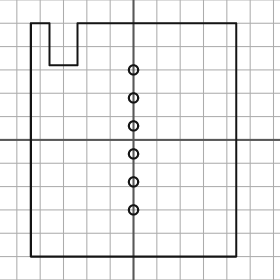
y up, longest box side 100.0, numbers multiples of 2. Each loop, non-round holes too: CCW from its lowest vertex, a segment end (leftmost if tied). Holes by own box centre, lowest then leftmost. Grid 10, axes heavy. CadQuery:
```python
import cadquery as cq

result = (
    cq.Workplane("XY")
    .moveTo(-44.0, -50.0)
    .lineTo(44.0, -50.0)
    .lineTo(44.0, 50.0)
    .lineTo(-24.0, 50.0)
    .lineTo(-24.0, 32.0)
    .lineTo(-36.0, 32.0)
    .lineTo(-36.0, 50.0)
    .lineTo(-44.0, 50.0)
    .close()
    .moveTo(0.0, -30.0)
    .circle(2.0)
    .moveTo(0.0, -18.0)
    .circle(2.0)
    .moveTo(0.0, -6.0)
    .circle(2.0)
    .moveTo(0.0, 6.0)
    .circle(2.0)
    .moveTo(0.0, 18.0)
    .circle(2.0)
    .moveTo(0.0, 30.0)
    .circle(2.0)
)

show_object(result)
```